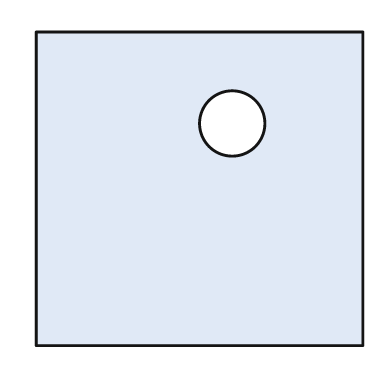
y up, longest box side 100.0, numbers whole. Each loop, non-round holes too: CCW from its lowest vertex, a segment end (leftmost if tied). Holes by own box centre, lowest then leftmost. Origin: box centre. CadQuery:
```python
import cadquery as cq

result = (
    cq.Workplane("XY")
    .moveTo(-50.0, -48.0)
    .lineTo(50.0, -48.0)
    .lineTo(50.0, 48.0)
    .lineTo(-50.0, 48.0)
    .close()
    .moveTo(10.0, 20.0)
    .circle(10.0)
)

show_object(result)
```